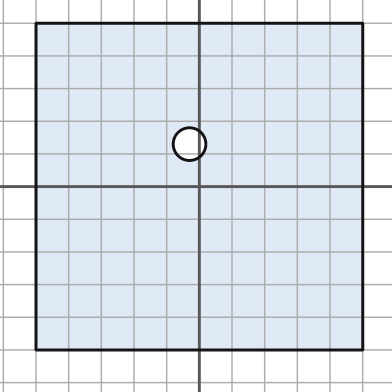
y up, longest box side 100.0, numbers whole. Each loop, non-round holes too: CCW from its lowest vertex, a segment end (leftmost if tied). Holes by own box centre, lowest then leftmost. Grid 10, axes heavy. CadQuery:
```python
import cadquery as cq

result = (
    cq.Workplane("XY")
    .moveTo(-50.0, -50.0)
    .lineTo(50.0, -50.0)
    .lineTo(50.0, 50.0)
    .lineTo(-50.0, 50.0)
    .close()
    .moveTo(-3.0, 13.0)
    .circle(5.0)
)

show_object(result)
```